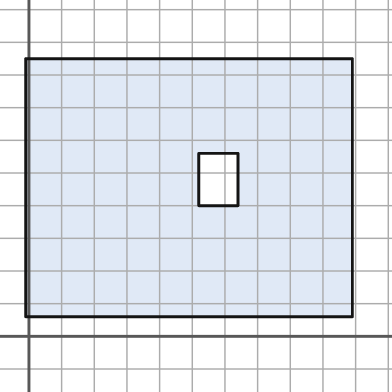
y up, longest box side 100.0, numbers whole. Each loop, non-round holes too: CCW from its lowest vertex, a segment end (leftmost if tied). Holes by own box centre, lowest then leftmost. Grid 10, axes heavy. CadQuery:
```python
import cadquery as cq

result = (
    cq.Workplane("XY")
    .moveTo(-1.0, 6.0)
    .lineTo(99.0, 6.0)
    .lineTo(99.0, 85.0)
    .lineTo(-1.0, 85.0)
    .close()
    .moveTo(52.0, 40.0)
    .lineTo(64.0, 40.0)
    .lineTo(64.0, 56.0)
    .lineTo(52.0, 56.0)
    .close()
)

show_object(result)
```